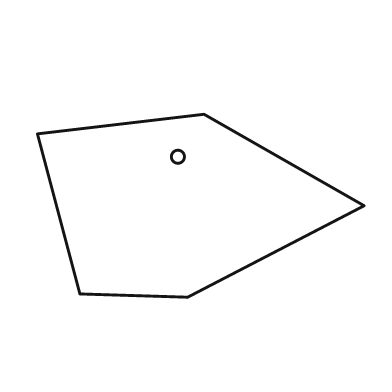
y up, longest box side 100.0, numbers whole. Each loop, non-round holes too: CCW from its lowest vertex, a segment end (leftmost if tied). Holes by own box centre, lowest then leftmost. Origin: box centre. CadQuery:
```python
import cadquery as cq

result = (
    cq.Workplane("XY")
    .moveTo(-4.0, -28.0)
    .lineTo(50.0, 0.0)
    .lineTo(1.0, 28.0)
    .lineTo(-50.0, 22.0)
    .lineTo(-37.0, -27.0)
    .close()
    .moveTo(-7.0, 15.0)
    .circle(2.0)
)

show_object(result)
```